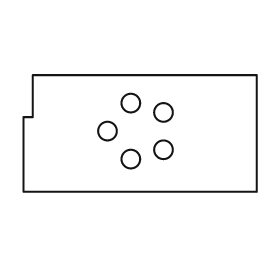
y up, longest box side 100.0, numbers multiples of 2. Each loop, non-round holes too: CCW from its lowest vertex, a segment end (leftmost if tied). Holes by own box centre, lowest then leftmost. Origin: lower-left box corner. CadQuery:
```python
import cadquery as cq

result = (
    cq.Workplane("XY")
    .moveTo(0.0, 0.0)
    .lineTo(100.0, 0.0)
    .lineTo(100.0, 50.0)
    .lineTo(4.0, 50.0)
    .lineTo(4.0, 32.0)
    .lineTo(0.0, 32.0)
    .close()
    .moveTo(46.0, 14.0)
    .circle(4.0)
    .moveTo(60.0, 18.0)
    .circle(4.0)
    .moveTo(36.0, 26.0)
    .circle(4.0)
    .moveTo(60.0, 34.0)
    .circle(4.0)
    .moveTo(46.0, 38.0)
    .circle(4.0)
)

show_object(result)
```